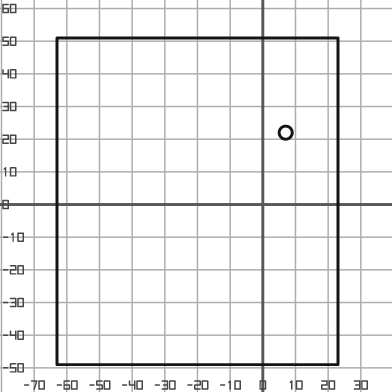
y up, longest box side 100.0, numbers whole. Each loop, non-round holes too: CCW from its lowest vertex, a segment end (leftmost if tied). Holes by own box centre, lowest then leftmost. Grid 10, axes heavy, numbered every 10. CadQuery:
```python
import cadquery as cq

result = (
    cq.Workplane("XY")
    .moveTo(-63.0, -49.0)
    .lineTo(23.0, -49.0)
    .lineTo(23.0, 51.0)
    .lineTo(-63.0, 51.0)
    .close()
    .moveTo(7.0, 22.0)
    .circle(2.0)
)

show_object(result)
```